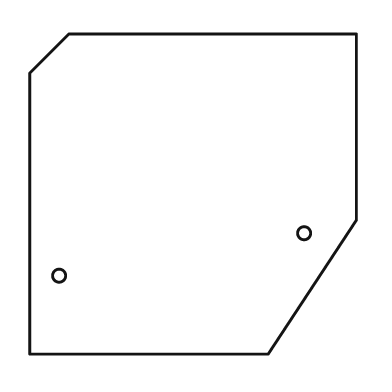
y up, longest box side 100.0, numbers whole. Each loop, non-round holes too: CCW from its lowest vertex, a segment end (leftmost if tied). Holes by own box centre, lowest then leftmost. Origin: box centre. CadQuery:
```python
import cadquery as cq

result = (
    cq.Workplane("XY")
    .moveTo(-50.0, -49.0)
    .lineTo(23.0, -49.0)
    .lineTo(50.0, -8.0)
    .lineTo(50.0, 49.0)
    .lineTo(-38.0, 49.0)
    .lineTo(-50.0, 37.0)
    .close()
    .moveTo(-41.0, -25.0)
    .circle(2.0)
    .moveTo(34.0, -12.0)
    .circle(2.0)
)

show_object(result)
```